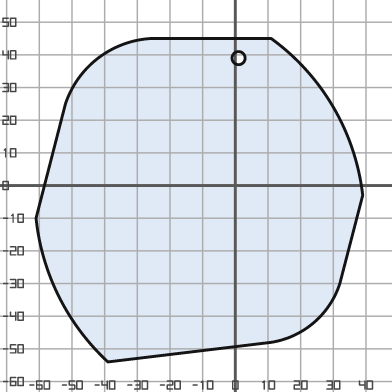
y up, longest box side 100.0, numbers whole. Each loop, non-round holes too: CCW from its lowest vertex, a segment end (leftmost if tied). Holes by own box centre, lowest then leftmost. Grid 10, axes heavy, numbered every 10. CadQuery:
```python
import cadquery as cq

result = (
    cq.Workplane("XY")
    .moveTo(-39.0, -54.0)
    .lineTo(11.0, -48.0)
    .threePointArc((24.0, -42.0), (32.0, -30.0))
    .lineTo(39.0, -3.0)
    .threePointArc((30.0, 24.0), (11.0, 45.0))
    .lineTo(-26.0, 45.0)
    .threePointArc((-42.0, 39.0), (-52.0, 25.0))
    .lineTo(-61.0, -10.0)
    .threePointArc((-54.0, -34.0), (-39.0, -54.0))
    .close()
    .moveTo(1.0, 39.0)
    .circle(2.0)
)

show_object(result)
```